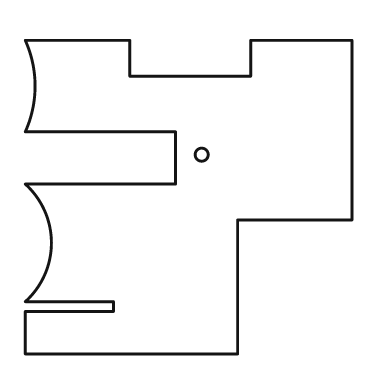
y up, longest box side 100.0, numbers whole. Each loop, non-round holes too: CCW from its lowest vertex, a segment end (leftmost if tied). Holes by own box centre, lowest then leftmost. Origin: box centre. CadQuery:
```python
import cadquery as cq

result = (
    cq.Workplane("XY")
    .moveTo(-50.0, -48.0)
    .lineTo(15.0, -48.0)
    .lineTo(15.0, -7.0)
    .lineTo(50.0, -7.0)
    .lineTo(50.0, 48.0)
    .lineTo(19.0, 48.0)
    .lineTo(19.0, 37.0)
    .lineTo(-18.0, 37.0)
    .lineTo(-18.0, 48.0)
    .lineTo(-50.0, 48.0)
    .threePointArc((-47.0, 34.0), (-50.0, 20.0))
    .lineTo(-4.0, 20.0)
    .lineTo(-4.0, 4.0)
    .lineTo(-50.0, 4.0)
    .threePointArc((-42.0, -14.0), (-50.0, -32.0))
    .lineTo(-23.0, -32.0)
    .lineTo(-23.0, -35.0)
    .lineTo(-50.0, -35.0)
    .close()
    .moveTo(4.0, 13.0)
    .circle(2.0)
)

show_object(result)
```